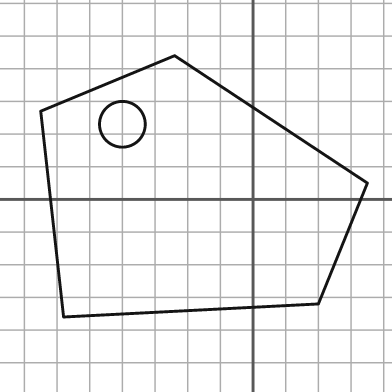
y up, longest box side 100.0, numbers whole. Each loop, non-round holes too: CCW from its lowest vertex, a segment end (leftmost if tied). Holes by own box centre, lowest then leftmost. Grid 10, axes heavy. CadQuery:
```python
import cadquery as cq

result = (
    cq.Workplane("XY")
    .moveTo(-58.0, -36.0)
    .lineTo(20.0, -32.0)
    .lineTo(35.0, 5.0)
    .lineTo(-24.0, 44.0)
    .lineTo(-65.0, 27.0)
    .close()
    .moveTo(-40.0, 23.0)
    .circle(7.0)
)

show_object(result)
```